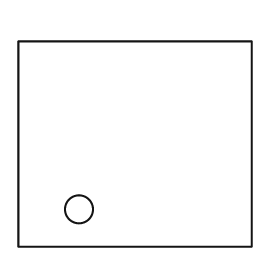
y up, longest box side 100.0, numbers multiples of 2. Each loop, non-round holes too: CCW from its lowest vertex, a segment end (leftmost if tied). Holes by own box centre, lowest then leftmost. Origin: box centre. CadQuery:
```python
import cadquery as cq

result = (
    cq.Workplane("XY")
    .moveTo(-50.0, -44.0)
    .lineTo(50.0, -44.0)
    .lineTo(50.0, 44.0)
    .lineTo(-50.0, 44.0)
    .close()
    .moveTo(-24.0, -28.0)
    .circle(6.0)
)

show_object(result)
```